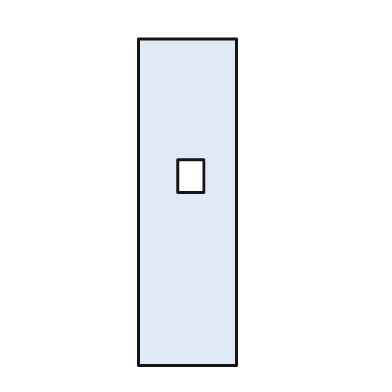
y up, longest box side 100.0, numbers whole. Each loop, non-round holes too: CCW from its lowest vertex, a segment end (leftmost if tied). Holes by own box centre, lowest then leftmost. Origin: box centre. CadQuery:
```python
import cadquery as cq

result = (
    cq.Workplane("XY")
    .moveTo(-15.0, -50.0)
    .lineTo(15.0, -50.0)
    .lineTo(15.0, 50.0)
    .lineTo(-15.0, 50.0)
    .close()
    .moveTo(-3.0, 3.0)
    .lineTo(5.0, 3.0)
    .lineTo(5.0, 13.0)
    .lineTo(-3.0, 13.0)
    .close()
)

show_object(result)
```